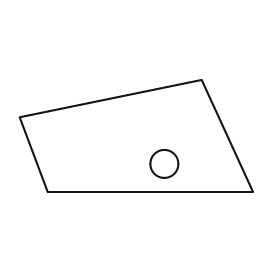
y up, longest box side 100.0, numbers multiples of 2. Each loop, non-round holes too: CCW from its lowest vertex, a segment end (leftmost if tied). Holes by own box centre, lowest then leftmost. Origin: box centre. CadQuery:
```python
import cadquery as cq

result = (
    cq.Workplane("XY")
    .moveTo(-38.0, -24.0)
    .lineTo(50.0, -24.0)
    .lineTo(28.0, 24.0)
    .lineTo(-50.0, 8.0)
    .close()
    .moveTo(12.0, -12.0)
    .circle(6.0)
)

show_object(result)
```